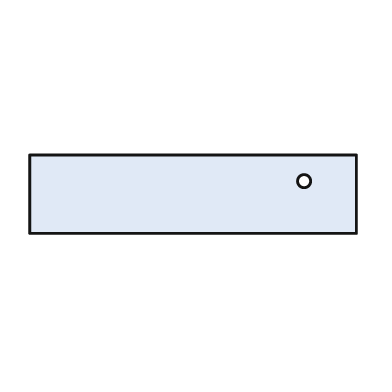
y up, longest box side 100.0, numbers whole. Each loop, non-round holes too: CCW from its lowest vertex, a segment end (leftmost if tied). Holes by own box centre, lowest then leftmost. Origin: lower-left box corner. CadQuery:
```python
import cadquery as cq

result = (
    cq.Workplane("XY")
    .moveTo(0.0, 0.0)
    .lineTo(100.0, 0.0)
    .lineTo(100.0, 24.0)
    .lineTo(0.0, 24.0)
    .close()
    .moveTo(84.0, 16.0)
    .circle(2.0)
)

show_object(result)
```